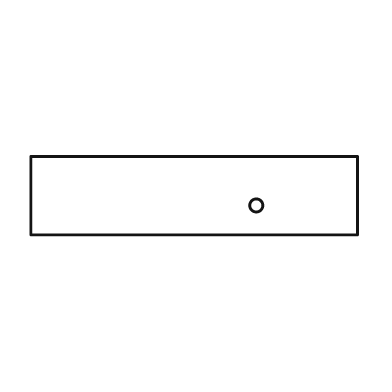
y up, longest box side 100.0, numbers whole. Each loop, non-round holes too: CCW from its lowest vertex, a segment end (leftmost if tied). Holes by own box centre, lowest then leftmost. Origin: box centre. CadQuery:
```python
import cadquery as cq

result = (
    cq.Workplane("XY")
    .moveTo(-50.0, -12.0)
    .lineTo(50.0, -12.0)
    .lineTo(50.0, 12.0)
    .lineTo(-50.0, 12.0)
    .close()
    .moveTo(19.0, -3.0)
    .circle(2.0)
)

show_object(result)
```